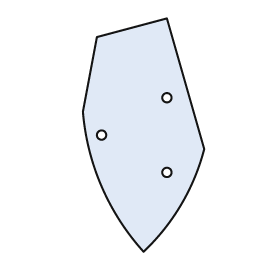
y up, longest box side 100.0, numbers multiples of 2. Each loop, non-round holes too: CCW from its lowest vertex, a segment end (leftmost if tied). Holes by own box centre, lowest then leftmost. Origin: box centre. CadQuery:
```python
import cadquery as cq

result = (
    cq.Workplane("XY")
    .moveTo(0.0, -50.0)
    .threePointArc((16.0, -30.0), (26.0, -6.0))
    .lineTo(10.0, 50.0)
    .lineTo(-20.0, 42.0)
    .lineTo(-26.0, 10.0)
    .threePointArc((-18.0, -22.0), (0.0, -50.0))
    .close()
    .moveTo(10.0, -16.0)
    .circle(2.0)
    .moveTo(-18.0, 0.0)
    .circle(2.0)
    .moveTo(10.0, 16.0)
    .circle(2.0)
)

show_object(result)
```